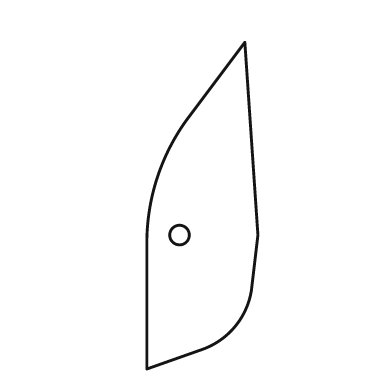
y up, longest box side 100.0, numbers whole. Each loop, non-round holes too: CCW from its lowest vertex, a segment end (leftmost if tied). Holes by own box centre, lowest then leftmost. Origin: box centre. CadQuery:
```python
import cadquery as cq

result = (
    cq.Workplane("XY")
    .moveTo(-17.0, -50.0)
    .lineTo(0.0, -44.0)
    .threePointArc((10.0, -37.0), (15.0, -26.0))
    .lineTo(17.0, -9.0)
    .lineTo(13.0, 50.0)
    .lineTo(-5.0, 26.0)
    .threePointArc((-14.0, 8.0), (-17.0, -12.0))
    .close()
    .moveTo(-7.0, -9.0)
    .circle(3.0)
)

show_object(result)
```